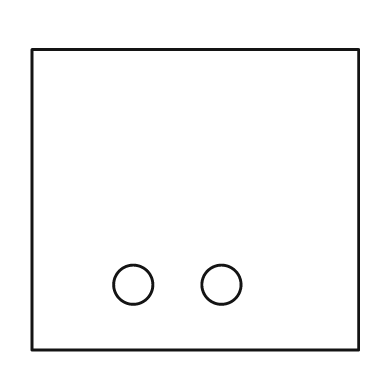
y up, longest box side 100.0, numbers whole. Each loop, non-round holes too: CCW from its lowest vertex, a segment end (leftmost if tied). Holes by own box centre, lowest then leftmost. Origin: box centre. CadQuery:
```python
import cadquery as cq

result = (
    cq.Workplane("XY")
    .moveTo(-50.0, -46.0)
    .lineTo(50.0, -46.0)
    .lineTo(50.0, 46.0)
    .lineTo(-50.0, 46.0)
    .close()
    .moveTo(-19.0, -26.0)
    .circle(6.0)
    .moveTo(8.0, -26.0)
    .circle(6.0)
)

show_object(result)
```